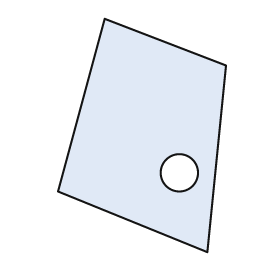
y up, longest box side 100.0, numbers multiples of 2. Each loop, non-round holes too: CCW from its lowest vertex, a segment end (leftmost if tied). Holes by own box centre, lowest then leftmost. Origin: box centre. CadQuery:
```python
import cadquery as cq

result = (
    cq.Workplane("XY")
    .moveTo(28.0, -50.0)
    .lineTo(36.0, 30.0)
    .lineTo(-16.0, 50.0)
    .lineTo(-36.0, -24.0)
    .close()
    .moveTo(16.0, -16.0)
    .circle(8.0)
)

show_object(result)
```